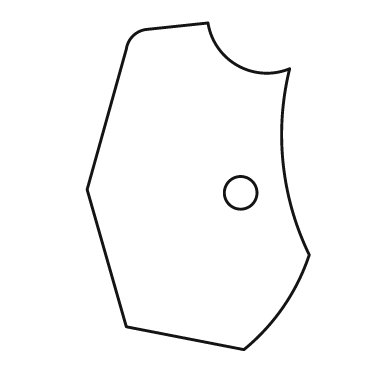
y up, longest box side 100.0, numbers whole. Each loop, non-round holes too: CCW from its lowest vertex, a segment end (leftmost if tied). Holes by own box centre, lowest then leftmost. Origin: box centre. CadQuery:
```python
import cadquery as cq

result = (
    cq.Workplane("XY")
    .moveTo(14.0, -50.0)
    .threePointArc((26.0, -37.0), (34.0, -21.0))
    .threePointArc((26.0, 7.0), (28.0, 36.0))
    .threePointArc((12.0, 37.0), (3.0, 50.0))
    .lineTo(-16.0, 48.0)
    .threePointArc((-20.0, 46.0), (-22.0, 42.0))
    .lineTo(-34.0, -1.0)
    .lineTo(-22.0, -43.0)
    .close()
    .moveTo(13.0, -2.0)
    .circle(5.0)
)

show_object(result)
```